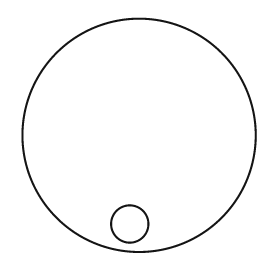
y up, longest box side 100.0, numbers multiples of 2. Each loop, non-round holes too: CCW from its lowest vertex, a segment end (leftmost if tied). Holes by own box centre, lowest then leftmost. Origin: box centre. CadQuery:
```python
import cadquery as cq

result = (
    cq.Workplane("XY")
    .moveTo(0.0, 0.0)
    .circle(50.0)
    .moveTo(-4.0, -38.0)
    .circle(8.0)
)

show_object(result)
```